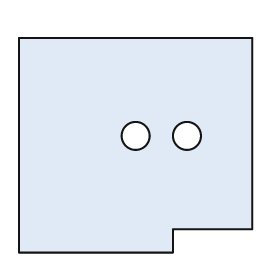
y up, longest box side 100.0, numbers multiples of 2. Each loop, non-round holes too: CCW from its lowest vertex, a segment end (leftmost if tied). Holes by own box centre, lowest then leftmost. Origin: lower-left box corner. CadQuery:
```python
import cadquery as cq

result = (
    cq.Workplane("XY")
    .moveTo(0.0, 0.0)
    .lineTo(66.0, 0.0)
    .lineTo(66.0, 10.0)
    .lineTo(100.0, 10.0)
    .lineTo(100.0, 92.0)
    .lineTo(0.0, 92.0)
    .close()
    .moveTo(50.0, 50.0)
    .circle(6.0)
    .moveTo(72.0, 50.0)
    .circle(6.0)
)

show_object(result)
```